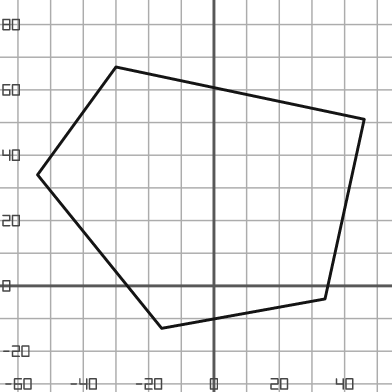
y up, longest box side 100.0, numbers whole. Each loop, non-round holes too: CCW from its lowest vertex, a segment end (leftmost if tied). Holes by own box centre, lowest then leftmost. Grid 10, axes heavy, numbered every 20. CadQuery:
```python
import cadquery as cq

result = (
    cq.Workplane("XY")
    .moveTo(-16.0, -13.0)
    .lineTo(34.0, -4.0)
    .lineTo(46.0, 51.0)
    .lineTo(-30.0, 67.0)
    .lineTo(-54.0, 34.0)
    .close()
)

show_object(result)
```